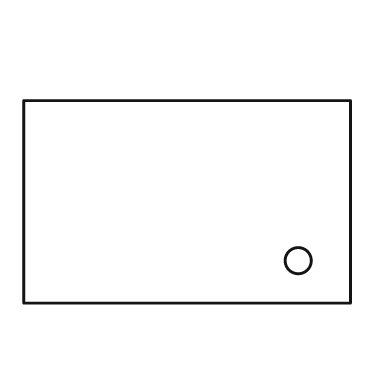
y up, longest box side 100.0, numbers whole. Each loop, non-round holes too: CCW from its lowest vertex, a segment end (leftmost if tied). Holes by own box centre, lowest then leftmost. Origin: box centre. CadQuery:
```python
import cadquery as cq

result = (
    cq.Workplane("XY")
    .moveTo(-50.0, -31.0)
    .lineTo(50.0, -31.0)
    .lineTo(50.0, 31.0)
    .lineTo(-50.0, 31.0)
    .close()
    .moveTo(34.0, -18.0)
    .circle(4.0)
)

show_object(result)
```